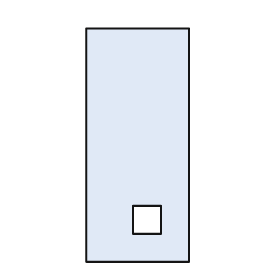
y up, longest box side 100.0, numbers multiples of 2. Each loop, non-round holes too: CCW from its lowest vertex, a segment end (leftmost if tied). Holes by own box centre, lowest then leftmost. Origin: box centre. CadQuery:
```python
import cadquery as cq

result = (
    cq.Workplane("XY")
    .moveTo(-22.0, -50.0)
    .lineTo(22.0, -50.0)
    .lineTo(22.0, 50.0)
    .lineTo(-22.0, 50.0)
    .close()
    .moveTo(-2.0, -38.0)
    .lineTo(10.0, -38.0)
    .lineTo(10.0, -26.0)
    .lineTo(-2.0, -26.0)
    .close()
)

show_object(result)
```